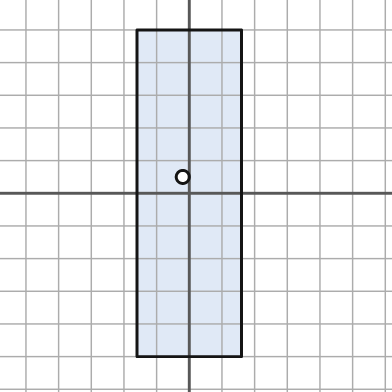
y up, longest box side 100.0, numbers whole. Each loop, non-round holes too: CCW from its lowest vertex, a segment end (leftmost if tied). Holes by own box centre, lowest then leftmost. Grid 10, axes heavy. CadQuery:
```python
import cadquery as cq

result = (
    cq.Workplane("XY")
    .moveTo(-16.0, -50.0)
    .lineTo(16.0, -50.0)
    .lineTo(16.0, 50.0)
    .lineTo(-16.0, 50.0)
    .close()
    .moveTo(-2.0, 5.0)
    .circle(2.0)
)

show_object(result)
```